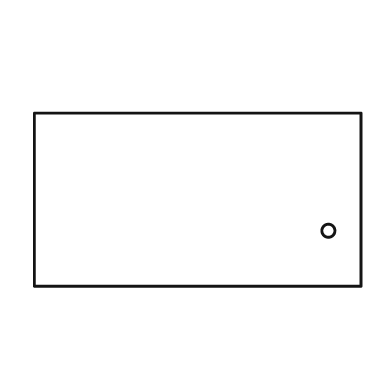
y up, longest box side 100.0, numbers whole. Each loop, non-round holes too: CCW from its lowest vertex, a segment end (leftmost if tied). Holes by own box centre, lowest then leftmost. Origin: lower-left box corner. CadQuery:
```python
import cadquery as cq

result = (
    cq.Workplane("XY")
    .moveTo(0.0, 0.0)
    .lineTo(100.0, 0.0)
    .lineTo(100.0, 53.0)
    .lineTo(0.0, 53.0)
    .close()
    .moveTo(90.0, 17.0)
    .circle(2.0)
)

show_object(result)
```